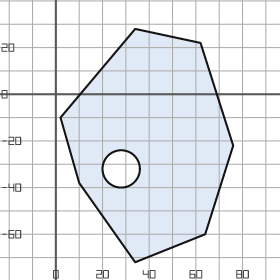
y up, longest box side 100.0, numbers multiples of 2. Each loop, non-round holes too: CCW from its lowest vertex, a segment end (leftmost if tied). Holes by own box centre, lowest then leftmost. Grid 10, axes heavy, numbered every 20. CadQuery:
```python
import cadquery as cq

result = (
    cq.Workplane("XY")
    .moveTo(34.0, -72.0)
    .lineTo(64.0, -60.0)
    .lineTo(76.0, -22.0)
    .lineTo(62.0, 22.0)
    .lineTo(34.0, 28.0)
    .lineTo(2.0, -10.0)
    .lineTo(10.0, -38.0)
    .close()
    .moveTo(28.0, -32.0)
    .circle(8.0)
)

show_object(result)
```